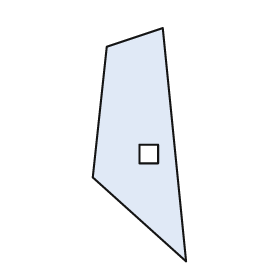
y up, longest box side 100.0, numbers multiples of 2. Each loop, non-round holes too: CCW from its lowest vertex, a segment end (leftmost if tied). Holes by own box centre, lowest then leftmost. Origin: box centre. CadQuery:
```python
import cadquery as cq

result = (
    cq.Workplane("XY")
    .moveTo(20.0, -50.0)
    .lineTo(10.0, 50.0)
    .lineTo(-14.0, 42.0)
    .lineTo(-20.0, -14.0)
    .close()
    .moveTo(0.0, -8.0)
    .lineTo(8.0, -8.0)
    .lineTo(8.0, 0.0)
    .lineTo(0.0, 0.0)
    .close()
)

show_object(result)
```